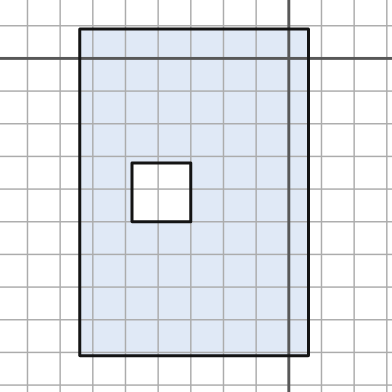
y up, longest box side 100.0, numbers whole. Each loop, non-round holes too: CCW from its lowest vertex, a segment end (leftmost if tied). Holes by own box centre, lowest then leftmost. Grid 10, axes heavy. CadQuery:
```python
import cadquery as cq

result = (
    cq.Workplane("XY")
    .moveTo(-64.0, -91.0)
    .lineTo(6.0, -91.0)
    .lineTo(6.0, 9.0)
    .lineTo(-64.0, 9.0)
    .close()
    .moveTo(-48.0, -50.0)
    .lineTo(-30.0, -50.0)
    .lineTo(-30.0, -32.0)
    .lineTo(-48.0, -32.0)
    .close()
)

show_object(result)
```